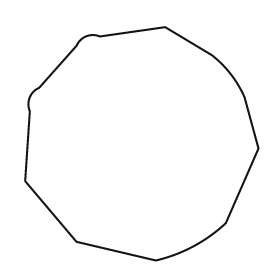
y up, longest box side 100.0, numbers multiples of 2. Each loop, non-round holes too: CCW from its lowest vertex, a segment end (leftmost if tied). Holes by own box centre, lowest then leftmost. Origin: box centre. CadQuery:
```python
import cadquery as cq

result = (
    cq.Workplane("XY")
    .moveTo(6.0, -50.0)
    .threePointArc((22.0, -44.0), (36.0, -34.0))
    .lineTo(50.0, -2.0)
    .lineTo(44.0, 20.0)
    .threePointArc((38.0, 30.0), (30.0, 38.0))
    .lineTo(10.0, 50.0)
    .lineTo(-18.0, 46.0)
    .threePointArc((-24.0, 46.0), (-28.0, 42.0))
    .lineTo(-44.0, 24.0)
    .threePointArc((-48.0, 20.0), (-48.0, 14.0))
    .lineTo(-50.0, -16.0)
    .lineTo(-28.0, -42.0)
    .close()
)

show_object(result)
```